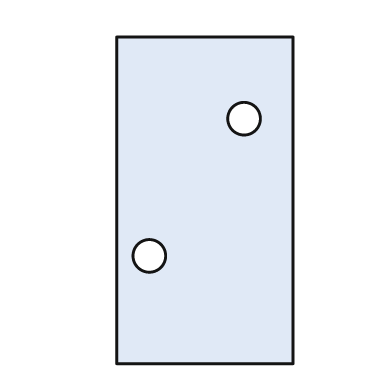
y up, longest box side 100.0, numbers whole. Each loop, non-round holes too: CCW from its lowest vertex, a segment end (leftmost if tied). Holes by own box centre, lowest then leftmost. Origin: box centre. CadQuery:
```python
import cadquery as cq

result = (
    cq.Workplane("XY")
    .moveTo(-27.0, -50.0)
    .lineTo(27.0, -50.0)
    .lineTo(27.0, 50.0)
    .lineTo(-27.0, 50.0)
    .close()
    .moveTo(-17.0, -17.0)
    .circle(5.0)
    .moveTo(12.0, 25.0)
    .circle(5.0)
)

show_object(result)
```